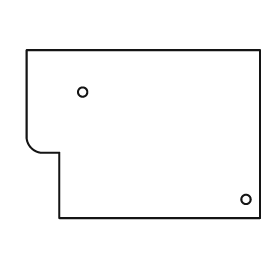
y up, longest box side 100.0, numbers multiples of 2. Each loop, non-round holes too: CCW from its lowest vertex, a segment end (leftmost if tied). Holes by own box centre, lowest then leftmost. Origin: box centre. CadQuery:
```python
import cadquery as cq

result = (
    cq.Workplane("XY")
    .moveTo(-36.0, -36.0)
    .lineTo(50.0, -36.0)
    .lineTo(50.0, 36.0)
    .lineTo(-50.0, 36.0)
    .lineTo(-50.0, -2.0)
    .threePointArc((-48.0, -6.0), (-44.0, -8.0))
    .lineTo(-36.0, -8.0)
    .close()
    .moveTo(44.0, -28.0)
    .circle(2.0)
    .moveTo(-26.0, 18.0)
    .circle(2.0)
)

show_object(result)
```